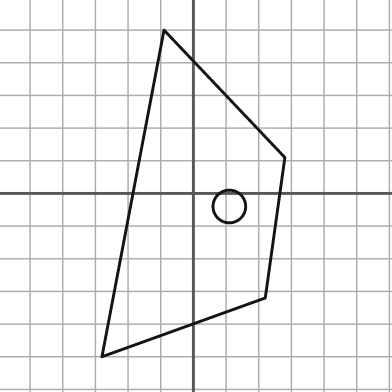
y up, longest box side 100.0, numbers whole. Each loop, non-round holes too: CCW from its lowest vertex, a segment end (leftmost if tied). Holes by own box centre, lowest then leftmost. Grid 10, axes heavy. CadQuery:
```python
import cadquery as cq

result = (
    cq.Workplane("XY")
    .moveTo(-28.0, -50.0)
    .lineTo(22.0, -32.0)
    .lineTo(28.0, 11.0)
    .lineTo(-9.0, 50.0)
    .close()
    .moveTo(11.0, -4.0)
    .circle(5.0)
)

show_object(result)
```